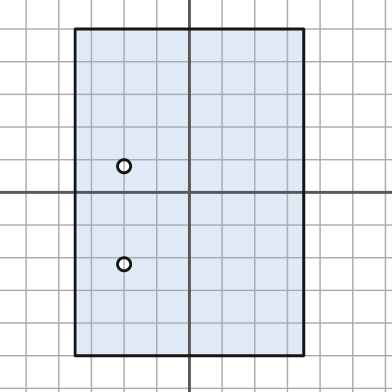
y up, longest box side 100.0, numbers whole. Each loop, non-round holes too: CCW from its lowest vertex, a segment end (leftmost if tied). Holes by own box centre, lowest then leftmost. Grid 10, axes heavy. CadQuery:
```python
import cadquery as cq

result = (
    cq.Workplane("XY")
    .moveTo(-35.0, -50.0)
    .lineTo(35.0, -50.0)
    .lineTo(35.0, 50.0)
    .lineTo(-35.0, 50.0)
    .close()
    .moveTo(-20.0, -22.0)
    .circle(2.0)
    .moveTo(-20.0, 8.0)
    .circle(2.0)
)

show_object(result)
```